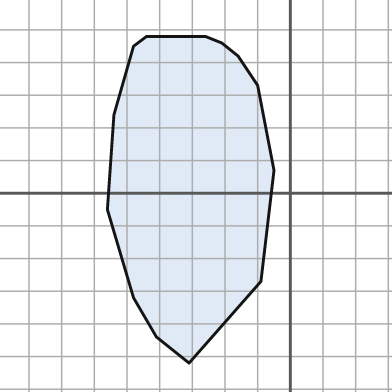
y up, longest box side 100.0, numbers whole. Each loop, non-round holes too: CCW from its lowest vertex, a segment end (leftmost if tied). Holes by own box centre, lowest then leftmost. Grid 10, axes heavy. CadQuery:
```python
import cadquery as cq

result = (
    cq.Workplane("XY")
    .moveTo(-31.0, -52.0)
    .lineTo(-9.0, -27.0)
    .lineTo(-5.0, 7.0)
    .lineTo(-10.0, 33.0)
    .lineTo(-16.0, 42.0)
    .lineTo(-21.0, 46.0)
    .lineTo(-26.0, 48.0)
    .lineTo(-44.0, 48.0)
    .lineTo(-48.0, 45.0)
    .lineTo(-54.0, 24.0)
    .lineTo(-56.0, -5.0)
    .lineTo(-48.0, -32.0)
    .lineTo(-41.0, -44.0)
    .close()
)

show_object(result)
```